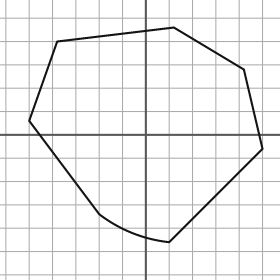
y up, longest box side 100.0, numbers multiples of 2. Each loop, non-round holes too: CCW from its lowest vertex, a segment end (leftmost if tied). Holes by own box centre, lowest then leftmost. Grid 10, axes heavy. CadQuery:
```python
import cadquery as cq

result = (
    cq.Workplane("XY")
    .moveTo(10.0, -46.0)
    .lineTo(50.0, -6.0)
    .lineTo(42.0, 28.0)
    .lineTo(12.0, 46.0)
    .lineTo(-38.0, 40.0)
    .lineTo(-50.0, 6.0)
    .lineTo(-20.0, -34.0)
    .threePointArc((-6.0, -42.0), (10.0, -46.0))
    .close()
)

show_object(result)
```